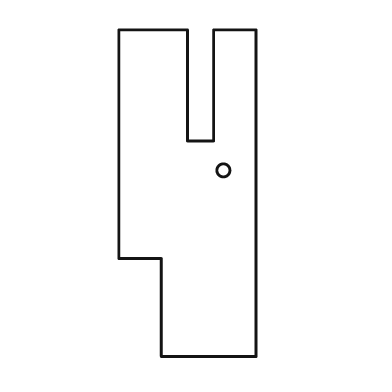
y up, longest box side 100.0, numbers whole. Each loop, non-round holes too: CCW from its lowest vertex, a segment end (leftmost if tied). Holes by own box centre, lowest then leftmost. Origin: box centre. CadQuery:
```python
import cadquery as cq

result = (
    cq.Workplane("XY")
    .moveTo(-8.0, -50.0)
    .lineTo(21.0, -50.0)
    .lineTo(21.0, 50.0)
    .lineTo(8.0, 50.0)
    .lineTo(8.0, 16.0)
    .lineTo(0.0, 16.0)
    .lineTo(0.0, 50.0)
    .lineTo(-21.0, 50.0)
    .lineTo(-21.0, -20.0)
    .lineTo(-8.0, -20.0)
    .close()
    .moveTo(11.0, 7.0)
    .circle(2.0)
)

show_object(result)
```